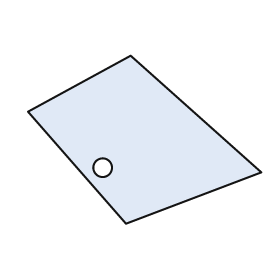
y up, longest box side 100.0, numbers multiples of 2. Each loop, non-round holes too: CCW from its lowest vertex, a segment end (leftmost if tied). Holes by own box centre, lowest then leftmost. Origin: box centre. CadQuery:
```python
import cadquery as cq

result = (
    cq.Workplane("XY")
    .moveTo(-8.0, -36.0)
    .lineTo(50.0, -14.0)
    .lineTo(-6.0, 36.0)
    .lineTo(-50.0, 12.0)
    .close()
    .moveTo(-18.0, -12.0)
    .circle(4.0)
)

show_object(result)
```